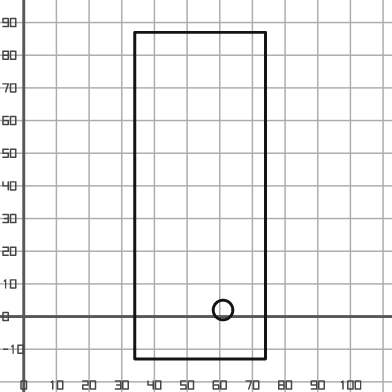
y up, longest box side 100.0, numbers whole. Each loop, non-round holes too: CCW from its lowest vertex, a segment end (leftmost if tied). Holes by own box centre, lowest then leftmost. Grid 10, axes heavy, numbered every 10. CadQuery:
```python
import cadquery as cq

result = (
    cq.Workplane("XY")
    .moveTo(34.0, -13.0)
    .lineTo(74.0, -13.0)
    .lineTo(74.0, 87.0)
    .lineTo(34.0, 87.0)
    .close()
    .moveTo(61.0, 2.0)
    .circle(3.0)
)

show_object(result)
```